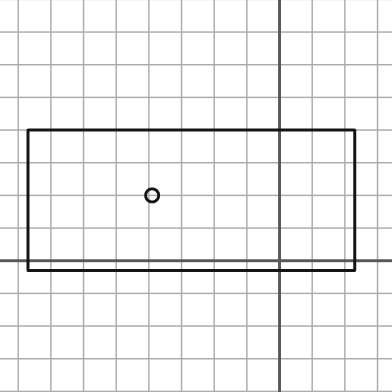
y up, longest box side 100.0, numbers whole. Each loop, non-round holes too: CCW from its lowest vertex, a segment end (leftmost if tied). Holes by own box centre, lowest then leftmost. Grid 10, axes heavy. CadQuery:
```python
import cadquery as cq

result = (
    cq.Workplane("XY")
    .moveTo(-77.0, -3.0)
    .lineTo(23.0, -3.0)
    .lineTo(23.0, 40.0)
    .lineTo(-77.0, 40.0)
    .close()
    .moveTo(-39.0, 20.0)
    .circle(2.0)
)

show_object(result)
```